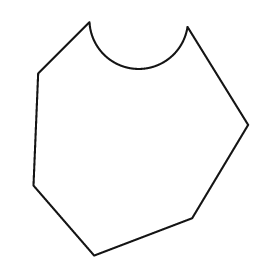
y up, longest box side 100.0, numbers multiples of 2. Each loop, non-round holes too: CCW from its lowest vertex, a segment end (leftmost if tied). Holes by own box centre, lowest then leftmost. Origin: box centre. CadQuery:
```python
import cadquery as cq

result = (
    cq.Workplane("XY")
    .moveTo(-20.0, -50.0)
    .lineTo(22.0, -34.0)
    .lineTo(46.0, 6.0)
    .lineTo(20.0, 48.0)
    .threePointArc((-2.0, 30.0), (-22.0, 50.0))
    .lineTo(-44.0, 28.0)
    .lineTo(-46.0, -20.0)
    .close()
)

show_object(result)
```